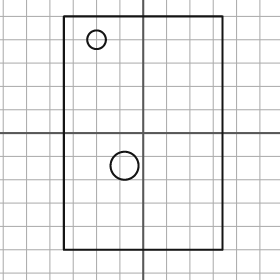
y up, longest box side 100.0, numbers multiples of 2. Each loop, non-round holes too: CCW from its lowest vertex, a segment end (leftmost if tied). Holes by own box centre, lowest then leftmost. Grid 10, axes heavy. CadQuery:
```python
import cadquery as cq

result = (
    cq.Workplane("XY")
    .moveTo(-34.0, -50.0)
    .lineTo(34.0, -50.0)
    .lineTo(34.0, 50.0)
    .lineTo(-34.0, 50.0)
    .close()
    .moveTo(-8.0, -14.0)
    .circle(6.0)
    .moveTo(-20.0, 40.0)
    .circle(4.0)
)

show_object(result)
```